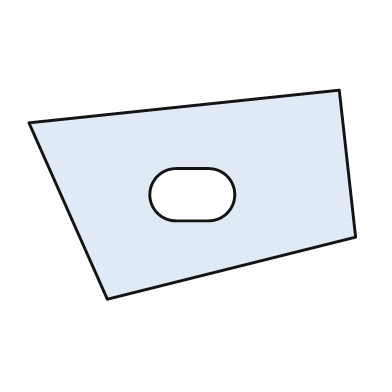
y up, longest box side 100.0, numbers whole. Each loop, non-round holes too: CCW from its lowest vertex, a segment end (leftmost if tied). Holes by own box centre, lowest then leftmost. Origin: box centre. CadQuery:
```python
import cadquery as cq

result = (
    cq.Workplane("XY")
    .moveTo(-26.0, -32.0)
    .lineTo(50.0, -13.0)
    .lineTo(45.0, 32.0)
    .lineTo(-50.0, 22.0)
    .close()
    .moveTo(-5.0, -8.0)
    .lineTo(5.0, -8.0)
    .threePointArc((13.0, 0.0), (5.0, 8.0))
    .lineTo(-5.0, 8.0)
    .threePointArc((-13.0, 0.0), (-5.0, -8.0))
    .close()
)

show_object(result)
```